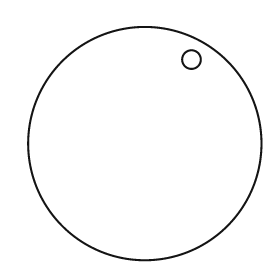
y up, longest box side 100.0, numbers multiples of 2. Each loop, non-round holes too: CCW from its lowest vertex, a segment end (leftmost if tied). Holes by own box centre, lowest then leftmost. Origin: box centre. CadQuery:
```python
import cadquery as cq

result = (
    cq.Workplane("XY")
    .moveTo(0.0, 0.0)
    .circle(50.0)
    .moveTo(20.0, 36.0)
    .circle(4.0)
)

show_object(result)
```